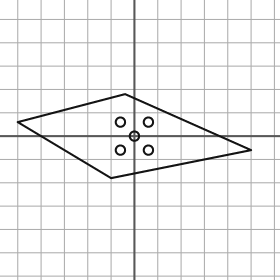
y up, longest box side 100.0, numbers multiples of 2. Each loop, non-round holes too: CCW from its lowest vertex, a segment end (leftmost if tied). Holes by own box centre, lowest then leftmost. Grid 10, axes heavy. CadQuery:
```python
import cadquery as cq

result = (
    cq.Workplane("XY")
    .moveTo(-10.0, -18.0)
    .lineTo(50.0, -6.0)
    .lineTo(-4.0, 18.0)
    .lineTo(-50.0, 6.0)
    .close()
    .moveTo(-6.0, -6.0)
    .circle(2.0)
    .moveTo(6.0, -6.0)
    .circle(2.0)
    .moveTo(0.0, 0.0)
    .circle(2.0)
    .moveTo(-6.0, 6.0)
    .circle(2.0)
    .moveTo(6.0, 6.0)
    .circle(2.0)
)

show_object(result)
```